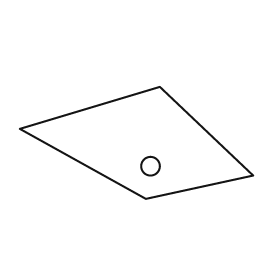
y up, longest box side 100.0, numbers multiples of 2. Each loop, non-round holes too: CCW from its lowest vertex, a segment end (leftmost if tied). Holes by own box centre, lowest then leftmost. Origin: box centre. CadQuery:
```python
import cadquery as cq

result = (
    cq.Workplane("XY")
    .moveTo(4.0, -24.0)
    .lineTo(50.0, -14.0)
    .lineTo(10.0, 24.0)
    .lineTo(-50.0, 6.0)
    .close()
    .moveTo(6.0, -10.0)
    .circle(4.0)
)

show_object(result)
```